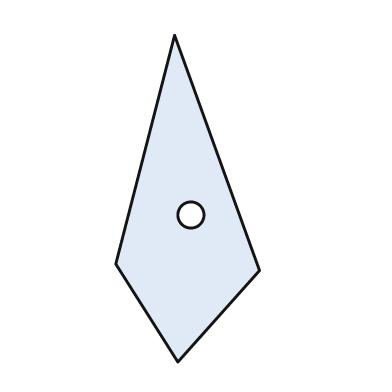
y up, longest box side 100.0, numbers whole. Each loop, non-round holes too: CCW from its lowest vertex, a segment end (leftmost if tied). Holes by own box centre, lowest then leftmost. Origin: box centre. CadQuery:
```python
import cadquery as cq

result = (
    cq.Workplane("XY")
    .moveTo(-3.0, -50.0)
    .lineTo(22.0, -22.0)
    .lineTo(-4.0, 50.0)
    .lineTo(-22.0, -20.0)
    .close()
    .moveTo(1.0, -5.0)
    .circle(4.0)
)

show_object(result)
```